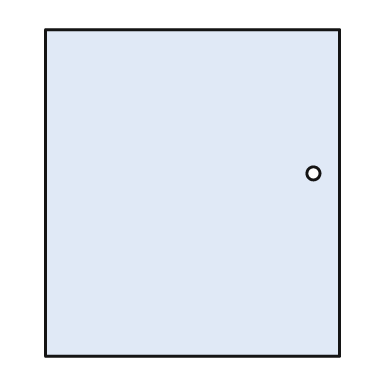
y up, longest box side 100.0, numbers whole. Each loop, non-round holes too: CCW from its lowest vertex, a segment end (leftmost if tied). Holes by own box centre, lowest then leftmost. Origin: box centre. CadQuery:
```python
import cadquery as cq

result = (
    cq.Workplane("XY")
    .moveTo(-45.0, -50.0)
    .lineTo(45.0, -50.0)
    .lineTo(45.0, 50.0)
    .lineTo(-45.0, 50.0)
    .close()
    .moveTo(37.0, 6.0)
    .circle(2.0)
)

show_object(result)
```